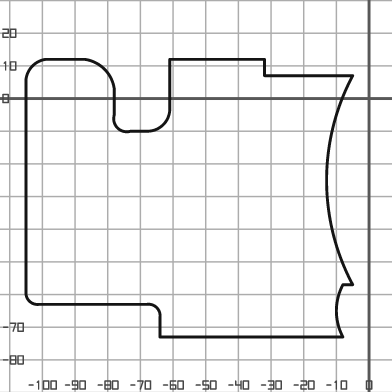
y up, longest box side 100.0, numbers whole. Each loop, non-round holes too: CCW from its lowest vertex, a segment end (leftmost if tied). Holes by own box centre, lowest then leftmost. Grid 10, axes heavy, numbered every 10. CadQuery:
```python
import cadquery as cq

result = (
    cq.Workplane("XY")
    .moveTo(-64.0, -73.0)
    .lineTo(-8.0, -73.0)
    .threePointArc((-10.0, -65.0), (-8.0, -57.0))
    .lineTo(-5.0, -57.0)
    .threePointArc((-13.0, -25.0), (-5.0, 7.0))
    .lineTo(-32.0, 7.0)
    .lineTo(-32.0, 12.0)
    .lineTo(-61.0, 12.0)
    .lineTo(-61.0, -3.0)
    .threePointArc((-63.0, -8.0), (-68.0, -10.0))
    .lineTo(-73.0, -10.0)
    .threePointArc((-77.0, -9.0), (-78.0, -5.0))
    .lineTo(-78.0, 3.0)
    .threePointArc((-81.0, 9.0), (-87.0, 12.0))
    .lineTo(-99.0, 12.0)
    .threePointArc((-103.0, 10.0), (-105.0, 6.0))
    .lineTo(-105.0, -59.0)
    .threePointArc((-104.0, -62.0), (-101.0, -63.0))
    .lineTo(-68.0, -63.0)
    .threePointArc((-65.0, -64.0), (-64.0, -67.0))
    .close()
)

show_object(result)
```